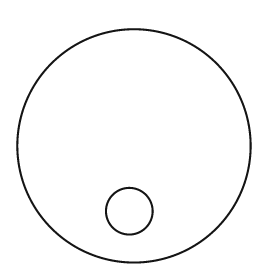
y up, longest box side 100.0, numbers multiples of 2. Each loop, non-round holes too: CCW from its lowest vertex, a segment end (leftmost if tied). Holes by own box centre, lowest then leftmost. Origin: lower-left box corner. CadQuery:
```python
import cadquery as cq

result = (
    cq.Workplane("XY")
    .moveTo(50.0, 50.0)
    .circle(50.0)
    .moveTo(48.0, 22.0)
    .circle(10.0)
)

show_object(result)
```